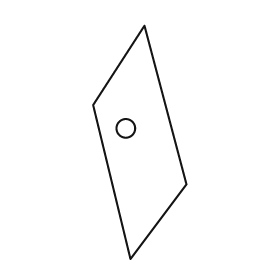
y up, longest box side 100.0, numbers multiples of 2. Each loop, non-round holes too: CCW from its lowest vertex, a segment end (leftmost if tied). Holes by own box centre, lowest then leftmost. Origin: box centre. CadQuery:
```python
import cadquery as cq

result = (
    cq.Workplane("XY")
    .moveTo(-4.0, -50.0)
    .lineTo(20.0, -18.0)
    .lineTo(2.0, 50.0)
    .lineTo(-20.0, 16.0)
    .close()
    .moveTo(-6.0, 6.0)
    .circle(4.0)
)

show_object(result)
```